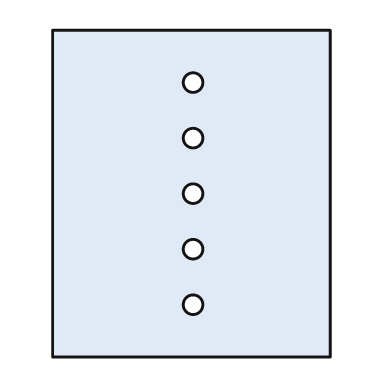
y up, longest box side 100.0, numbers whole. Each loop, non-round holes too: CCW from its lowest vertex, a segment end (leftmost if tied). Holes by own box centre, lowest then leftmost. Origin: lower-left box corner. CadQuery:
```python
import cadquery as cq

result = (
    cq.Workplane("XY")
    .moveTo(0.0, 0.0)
    .lineTo(85.0, 0.0)
    .lineTo(85.0, 100.0)
    .lineTo(0.0, 100.0)
    .close()
    .moveTo(43.0, 16.0)
    .circle(3.0)
    .moveTo(43.0, 33.0)
    .circle(3.0)
    .moveTo(43.0, 50.0)
    .circle(3.0)
    .moveTo(43.0, 67.0)
    .circle(3.0)
    .moveTo(43.0, 84.0)
    .circle(3.0)
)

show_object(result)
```